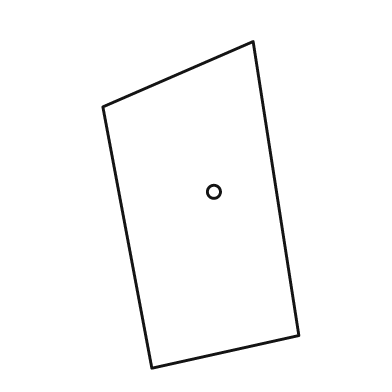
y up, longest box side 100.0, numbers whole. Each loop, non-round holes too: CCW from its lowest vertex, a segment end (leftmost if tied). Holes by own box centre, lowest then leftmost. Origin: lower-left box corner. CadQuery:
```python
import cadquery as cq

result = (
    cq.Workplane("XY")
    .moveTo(15.0, 0.0)
    .lineTo(60.0, 10.0)
    .lineTo(46.0, 100.0)
    .lineTo(0.0, 80.0)
    .close()
    .moveTo(34.0, 54.0)
    .circle(2.0)
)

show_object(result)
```